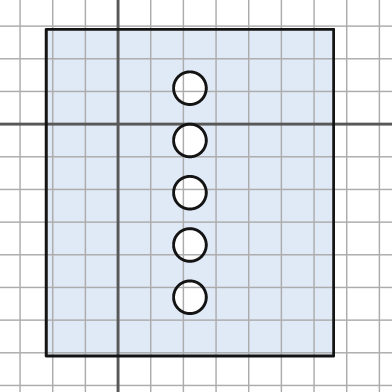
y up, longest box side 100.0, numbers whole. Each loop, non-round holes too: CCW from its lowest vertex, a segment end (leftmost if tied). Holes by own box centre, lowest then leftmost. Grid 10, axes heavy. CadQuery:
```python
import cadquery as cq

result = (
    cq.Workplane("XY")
    .moveTo(-22.0, -71.0)
    .lineTo(66.0, -71.0)
    .lineTo(66.0, 29.0)
    .lineTo(-22.0, 29.0)
    .close()
    .moveTo(22.0, -53.0)
    .circle(5.0)
    .moveTo(22.0, -37.0)
    .circle(5.0)
    .moveTo(22.0, -21.0)
    .circle(5.0)
    .moveTo(22.0, -5.0)
    .circle(5.0)
    .moveTo(22.0, 11.0)
    .circle(5.0)
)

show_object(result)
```